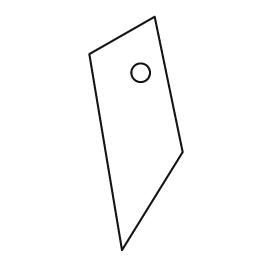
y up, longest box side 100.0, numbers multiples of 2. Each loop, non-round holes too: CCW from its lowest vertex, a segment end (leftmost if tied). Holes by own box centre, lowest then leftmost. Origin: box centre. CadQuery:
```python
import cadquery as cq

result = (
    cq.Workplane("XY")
    .moveTo(-6.0, -50.0)
    .lineTo(20.0, -8.0)
    .lineTo(8.0, 50.0)
    .lineTo(-20.0, 34.0)
    .close()
    .moveTo(2.0, 26.0)
    .circle(4.0)
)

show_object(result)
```